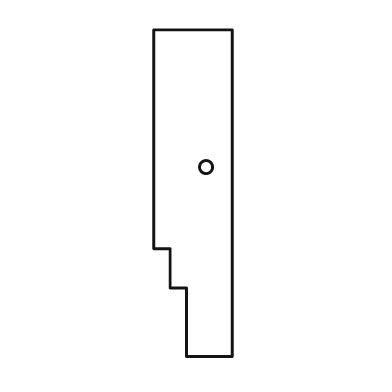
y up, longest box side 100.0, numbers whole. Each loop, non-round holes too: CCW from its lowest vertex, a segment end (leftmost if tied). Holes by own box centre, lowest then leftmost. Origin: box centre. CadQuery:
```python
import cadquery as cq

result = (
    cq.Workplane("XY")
    .moveTo(-2.0, -50.0)
    .lineTo(12.0, -50.0)
    .lineTo(12.0, 50.0)
    .lineTo(-12.0, 50.0)
    .lineTo(-12.0, -17.0)
    .lineTo(-7.0, -17.0)
    .lineTo(-7.0, -29.0)
    .lineTo(-2.0, -29.0)
    .close()
    .moveTo(4.0, 8.0)
    .circle(2.0)
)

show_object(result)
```